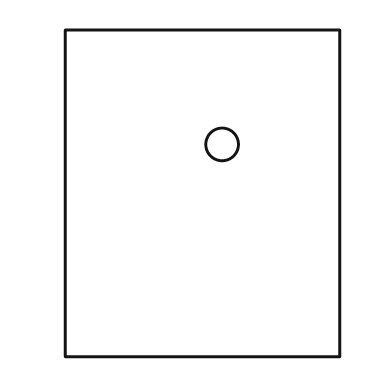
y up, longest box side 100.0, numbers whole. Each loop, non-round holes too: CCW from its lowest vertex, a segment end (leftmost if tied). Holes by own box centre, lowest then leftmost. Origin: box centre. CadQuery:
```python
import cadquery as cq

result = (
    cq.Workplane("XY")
    .moveTo(-42.0, -50.0)
    .lineTo(42.0, -50.0)
    .lineTo(42.0, 50.0)
    .lineTo(-42.0, 50.0)
    .close()
    .moveTo(6.0, 15.0)
    .circle(5.0)
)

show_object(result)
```